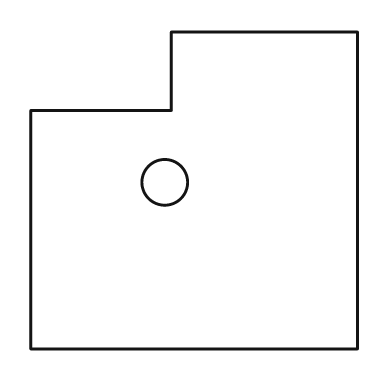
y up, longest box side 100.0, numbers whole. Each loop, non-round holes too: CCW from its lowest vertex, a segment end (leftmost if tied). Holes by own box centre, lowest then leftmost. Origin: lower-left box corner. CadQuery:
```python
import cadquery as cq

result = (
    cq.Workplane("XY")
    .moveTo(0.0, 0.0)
    .lineTo(100.0, 0.0)
    .lineTo(100.0, 97.0)
    .lineTo(43.0, 97.0)
    .lineTo(43.0, 73.0)
    .lineTo(0.0, 73.0)
    .close()
    .moveTo(41.0, 51.0)
    .circle(7.0)
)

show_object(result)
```